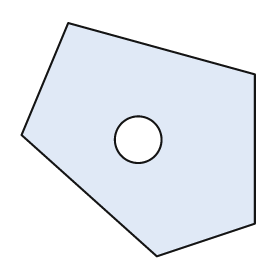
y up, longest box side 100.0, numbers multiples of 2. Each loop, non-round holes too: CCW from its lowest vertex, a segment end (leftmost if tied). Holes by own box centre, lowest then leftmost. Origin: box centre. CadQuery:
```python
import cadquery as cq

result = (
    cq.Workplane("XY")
    .moveTo(8.0, -50.0)
    .lineTo(50.0, -36.0)
    .lineTo(50.0, 28.0)
    .lineTo(-30.0, 50.0)
    .lineTo(-50.0, 2.0)
    .close()
    .moveTo(0.0, 0.0)
    .circle(10.0)
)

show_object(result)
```